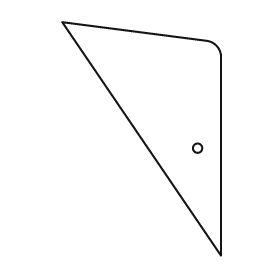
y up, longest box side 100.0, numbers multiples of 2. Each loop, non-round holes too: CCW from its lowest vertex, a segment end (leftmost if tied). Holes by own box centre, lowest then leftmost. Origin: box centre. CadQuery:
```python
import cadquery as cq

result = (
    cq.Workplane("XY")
    .moveTo(34.0, -50.0)
    .lineTo(34.0, 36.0)
    .threePointArc((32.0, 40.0), (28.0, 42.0))
    .lineTo(-34.0, 50.0)
    .close()
    .moveTo(24.0, -4.0)
    .circle(2.0)
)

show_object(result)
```